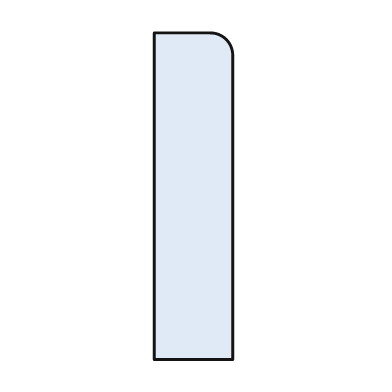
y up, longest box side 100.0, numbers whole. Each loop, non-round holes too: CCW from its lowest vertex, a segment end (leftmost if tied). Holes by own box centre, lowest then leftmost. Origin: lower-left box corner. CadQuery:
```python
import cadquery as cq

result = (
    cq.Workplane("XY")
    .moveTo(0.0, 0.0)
    .lineTo(24.0, 0.0)
    .lineTo(24.0, 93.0)
    .threePointArc((22.0, 98.0), (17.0, 100.0))
    .lineTo(0.0, 100.0)
    .close()
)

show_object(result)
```